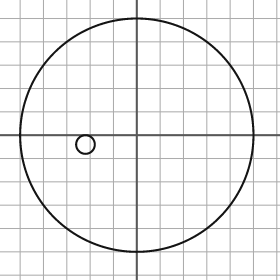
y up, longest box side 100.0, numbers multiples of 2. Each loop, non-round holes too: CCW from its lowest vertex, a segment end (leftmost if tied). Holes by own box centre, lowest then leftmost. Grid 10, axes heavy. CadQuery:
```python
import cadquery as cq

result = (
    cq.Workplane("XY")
    .moveTo(0.0, 0.0)
    .circle(50.0)
    .moveTo(-22.0, -4.0)
    .circle(4.0)
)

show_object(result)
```